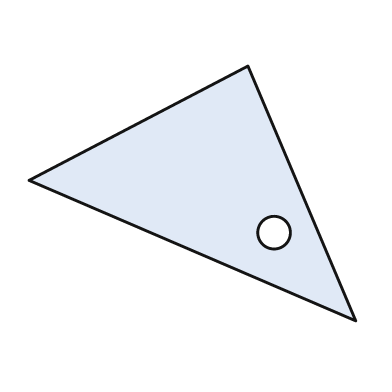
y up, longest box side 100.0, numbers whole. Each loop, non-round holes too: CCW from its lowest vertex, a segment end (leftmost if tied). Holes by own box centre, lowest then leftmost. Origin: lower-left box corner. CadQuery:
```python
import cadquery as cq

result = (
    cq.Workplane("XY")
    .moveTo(100.0, 0.0)
    .lineTo(67.0, 78.0)
    .lineTo(0.0, 43.0)
    .close()
    .moveTo(75.0, 27.0)
    .circle(5.0)
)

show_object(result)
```